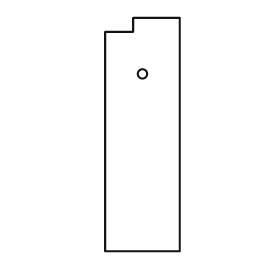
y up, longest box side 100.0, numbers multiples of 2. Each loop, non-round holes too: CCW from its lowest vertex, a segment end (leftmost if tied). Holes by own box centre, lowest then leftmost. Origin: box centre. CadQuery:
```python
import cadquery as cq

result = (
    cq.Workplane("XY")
    .moveTo(-16.0, -50.0)
    .lineTo(16.0, -50.0)
    .lineTo(16.0, 50.0)
    .lineTo(-4.0, 50.0)
    .lineTo(-4.0, 44.0)
    .lineTo(-16.0, 44.0)
    .close()
    .moveTo(0.0, 26.0)
    .circle(2.0)
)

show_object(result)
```